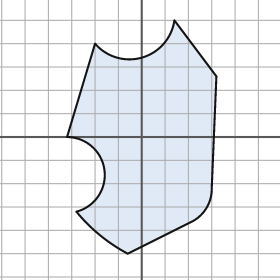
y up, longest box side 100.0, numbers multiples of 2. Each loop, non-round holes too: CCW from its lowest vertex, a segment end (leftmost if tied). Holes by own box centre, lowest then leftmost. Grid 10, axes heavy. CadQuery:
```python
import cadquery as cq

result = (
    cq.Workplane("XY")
    .moveTo(-6.0, -50.0)
    .lineTo(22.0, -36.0)
    .threePointArc((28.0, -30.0), (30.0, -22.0))
    .lineTo(32.0, 26.0)
    .lineTo(14.0, 50.0)
    .threePointArc((0.0, 34.0), (-20.0, 40.0))
    .lineTo(-32.0, 0.0)
    .threePointArc((-16.0, -14.0), (-28.0, -32.0))
    .threePointArc((-18.0, -42.0), (-6.0, -50.0))
    .close()
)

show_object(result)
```